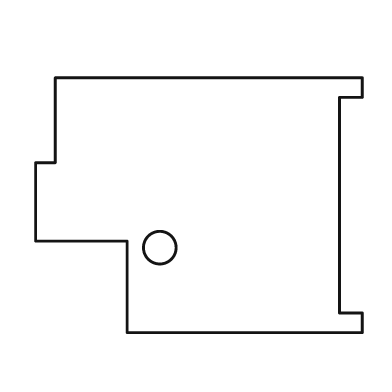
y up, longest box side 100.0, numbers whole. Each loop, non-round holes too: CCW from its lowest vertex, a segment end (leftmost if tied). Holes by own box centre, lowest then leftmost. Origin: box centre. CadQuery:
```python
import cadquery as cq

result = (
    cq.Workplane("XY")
    .moveTo(-22.0, -39.0)
    .lineTo(50.0, -39.0)
    .lineTo(50.0, -33.0)
    .lineTo(43.0, -33.0)
    .lineTo(43.0, 33.0)
    .lineTo(50.0, 33.0)
    .lineTo(50.0, 39.0)
    .lineTo(-44.0, 39.0)
    .lineTo(-44.0, 13.0)
    .lineTo(-50.0, 13.0)
    .lineTo(-50.0, -11.0)
    .lineTo(-22.0, -11.0)
    .close()
    .moveTo(-12.0, -13.0)
    .circle(5.0)
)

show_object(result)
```